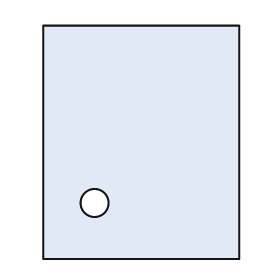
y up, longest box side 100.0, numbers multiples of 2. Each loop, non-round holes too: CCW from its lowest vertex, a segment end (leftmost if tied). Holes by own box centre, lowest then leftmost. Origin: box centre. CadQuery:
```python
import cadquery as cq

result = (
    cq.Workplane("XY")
    .moveTo(-42.0, -50.0)
    .lineTo(42.0, -50.0)
    .lineTo(42.0, 50.0)
    .lineTo(-42.0, 50.0)
    .close()
    .moveTo(-20.0, -26.0)
    .circle(6.0)
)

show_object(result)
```